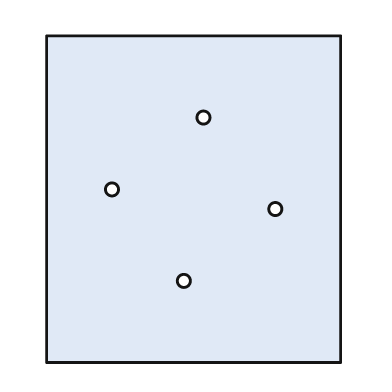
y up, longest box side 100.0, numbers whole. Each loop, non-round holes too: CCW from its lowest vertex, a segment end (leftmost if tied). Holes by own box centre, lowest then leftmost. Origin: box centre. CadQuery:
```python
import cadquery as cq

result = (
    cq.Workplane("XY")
    .moveTo(-45.0, -50.0)
    .lineTo(45.0, -50.0)
    .lineTo(45.0, 50.0)
    .lineTo(-45.0, 50.0)
    .close()
    .moveTo(-3.0, -25.0)
    .circle(2.0)
    .moveTo(25.0, -3.0)
    .circle(2.0)
    .moveTo(-25.0, 3.0)
    .circle(2.0)
    .moveTo(3.0, 25.0)
    .circle(2.0)
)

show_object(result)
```